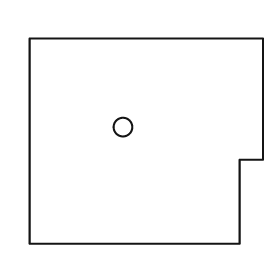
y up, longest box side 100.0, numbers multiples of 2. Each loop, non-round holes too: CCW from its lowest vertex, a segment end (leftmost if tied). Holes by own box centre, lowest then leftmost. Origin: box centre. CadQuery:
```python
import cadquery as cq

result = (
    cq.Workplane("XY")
    .moveTo(-50.0, -44.0)
    .lineTo(40.0, -44.0)
    .lineTo(40.0, -8.0)
    .lineTo(50.0, -8.0)
    .lineTo(50.0, 44.0)
    .lineTo(-50.0, 44.0)
    .close()
    .moveTo(-10.0, 6.0)
    .circle(4.0)
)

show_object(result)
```